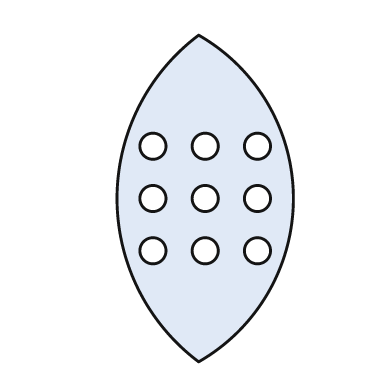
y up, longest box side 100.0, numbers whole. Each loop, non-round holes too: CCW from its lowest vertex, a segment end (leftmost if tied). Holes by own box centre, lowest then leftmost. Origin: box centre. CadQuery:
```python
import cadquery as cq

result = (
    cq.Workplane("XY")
    .moveTo(-2.0, -50.0)
    .threePointArc((27.0, 0.0), (-2.0, 50.0))
    .threePointArc((-27.0, 0.0), (-2.0, -50.0))
    .close()
    .moveTo(-16.0, -16.0)
    .circle(4.0)
    .moveTo(0.0, -16.0)
    .circle(4.0)
    .moveTo(16.0, -16.0)
    .circle(4.0)
    .moveTo(-16.0, 0.0)
    .circle(4.0)
    .moveTo(0.0, 0.0)
    .circle(4.0)
    .moveTo(16.0, 0.0)
    .circle(4.0)
    .moveTo(-16.0, 16.0)
    .circle(4.0)
    .moveTo(0.0, 16.0)
    .circle(4.0)
    .moveTo(16.0, 16.0)
    .circle(4.0)
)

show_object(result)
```